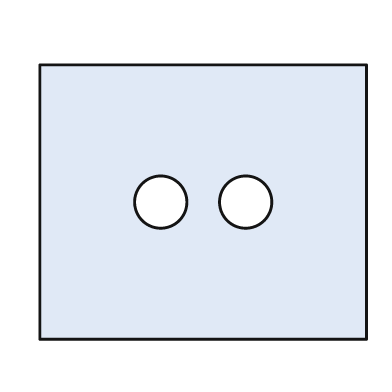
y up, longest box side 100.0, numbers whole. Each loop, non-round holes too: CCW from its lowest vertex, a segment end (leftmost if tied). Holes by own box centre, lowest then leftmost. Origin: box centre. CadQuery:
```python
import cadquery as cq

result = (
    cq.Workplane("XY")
    .moveTo(-50.0, -42.0)
    .lineTo(50.0, -42.0)
    .lineTo(50.0, 42.0)
    .lineTo(-50.0, 42.0)
    .close()
    .moveTo(-13.0, 0.0)
    .circle(8.0)
    .moveTo(13.0, 0.0)
    .circle(8.0)
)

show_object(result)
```